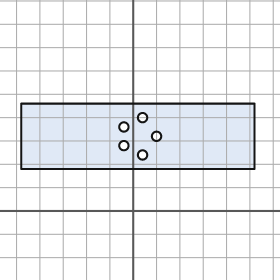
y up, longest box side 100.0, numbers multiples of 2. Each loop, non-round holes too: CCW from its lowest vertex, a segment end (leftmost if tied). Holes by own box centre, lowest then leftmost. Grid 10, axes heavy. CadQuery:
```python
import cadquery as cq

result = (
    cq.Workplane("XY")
    .moveTo(-48.0, 18.0)
    .lineTo(52.0, 18.0)
    .lineTo(52.0, 46.0)
    .lineTo(-48.0, 46.0)
    .close()
    .moveTo(4.0, 24.0)
    .circle(2.0)
    .moveTo(-4.0, 28.0)
    .circle(2.0)
    .moveTo(10.0, 32.0)
    .circle(2.0)
    .moveTo(-4.0, 36.0)
    .circle(2.0)
    .moveTo(4.0, 40.0)
    .circle(2.0)
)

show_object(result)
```